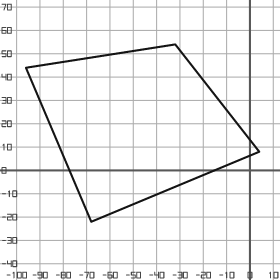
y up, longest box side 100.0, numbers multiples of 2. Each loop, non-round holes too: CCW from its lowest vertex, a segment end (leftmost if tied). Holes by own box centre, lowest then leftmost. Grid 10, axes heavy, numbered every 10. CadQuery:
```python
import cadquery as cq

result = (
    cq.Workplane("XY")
    .moveTo(-68.0, -22.0)
    .lineTo(4.0, 8.0)
    .lineTo(-32.0, 54.0)
    .lineTo(-96.0, 44.0)
    .close()
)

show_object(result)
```